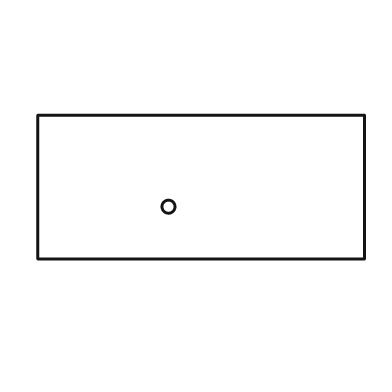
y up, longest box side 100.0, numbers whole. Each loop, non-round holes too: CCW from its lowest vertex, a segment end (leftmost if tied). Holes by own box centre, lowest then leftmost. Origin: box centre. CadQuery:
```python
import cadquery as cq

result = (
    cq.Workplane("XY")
    .moveTo(-50.0, -22.0)
    .lineTo(50.0, -22.0)
    .lineTo(50.0, 22.0)
    .lineTo(-50.0, 22.0)
    .close()
    .moveTo(-10.0, -6.0)
    .circle(2.0)
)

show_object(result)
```